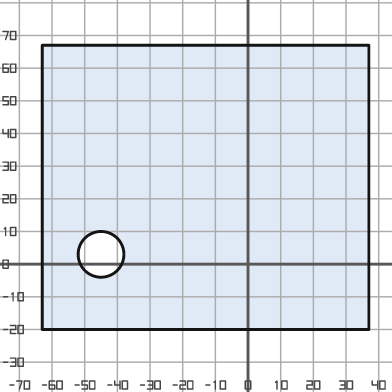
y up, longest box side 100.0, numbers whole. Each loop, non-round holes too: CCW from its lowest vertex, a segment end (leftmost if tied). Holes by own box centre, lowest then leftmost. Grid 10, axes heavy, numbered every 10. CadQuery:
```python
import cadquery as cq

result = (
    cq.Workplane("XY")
    .moveTo(-63.0, -20.0)
    .lineTo(37.0, -20.0)
    .lineTo(37.0, 67.0)
    .lineTo(-63.0, 67.0)
    .close()
    .moveTo(-45.0, 3.0)
    .circle(7.0)
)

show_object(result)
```